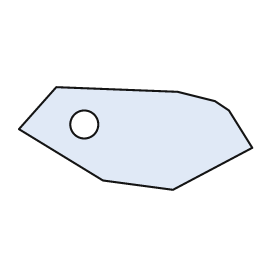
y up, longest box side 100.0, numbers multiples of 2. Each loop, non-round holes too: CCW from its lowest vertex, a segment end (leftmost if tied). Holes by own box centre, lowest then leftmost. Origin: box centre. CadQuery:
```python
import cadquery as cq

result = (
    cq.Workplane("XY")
    .moveTo(16.0, -22.0)
    .lineTo(50.0, -4.0)
    .lineTo(40.0, 12.0)
    .lineTo(34.0, 16.0)
    .lineTo(18.0, 20.0)
    .lineTo(-34.0, 22.0)
    .lineTo(-50.0, 4.0)
    .lineTo(-14.0, -18.0)
    .close()
    .moveTo(-22.0, 6.0)
    .circle(6.0)
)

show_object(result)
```